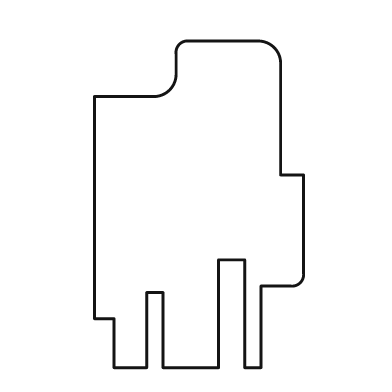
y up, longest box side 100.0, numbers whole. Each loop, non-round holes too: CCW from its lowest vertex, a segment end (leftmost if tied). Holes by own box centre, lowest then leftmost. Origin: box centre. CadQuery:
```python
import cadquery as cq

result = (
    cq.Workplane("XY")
    .moveTo(-26.0, -50.0)
    .lineTo(-16.0, -50.0)
    .lineTo(-16.0, -27.0)
    .lineTo(-11.0, -27.0)
    .lineTo(-11.0, -50.0)
    .lineTo(6.0, -50.0)
    .lineTo(6.0, -17.0)
    .lineTo(14.0, -17.0)
    .lineTo(14.0, -50.0)
    .lineTo(19.0, -50.0)
    .lineTo(19.0, -25.0)
    .lineTo(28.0, -25.0)
    .threePointArc((31.0, -24.0), (32.0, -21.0))
    .lineTo(32.0, 9.0)
    .lineTo(25.0, 9.0)
    .lineTo(25.0, 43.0)
    .threePointArc((23.0, 48.0), (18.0, 50.0))
    .lineTo(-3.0, 50.0)
    .threePointArc((-6.0, 49.0), (-7.0, 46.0))
    .lineTo(-7.0, 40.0)
    .threePointArc((-9.0, 35.0), (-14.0, 33.0))
    .lineTo(-32.0, 33.0)
    .lineTo(-32.0, -35.0)
    .lineTo(-26.0, -35.0)
    .close()
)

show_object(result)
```